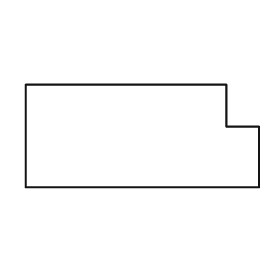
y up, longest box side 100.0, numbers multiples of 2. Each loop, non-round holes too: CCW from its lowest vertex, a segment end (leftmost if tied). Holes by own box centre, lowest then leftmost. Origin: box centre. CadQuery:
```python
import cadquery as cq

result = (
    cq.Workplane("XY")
    .moveTo(-50.0, -22.0)
    .lineTo(50.0, -22.0)
    .lineTo(50.0, 4.0)
    .lineTo(36.0, 4.0)
    .lineTo(36.0, 22.0)
    .lineTo(-50.0, 22.0)
    .close()
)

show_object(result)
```